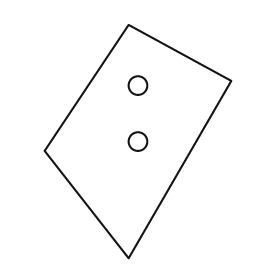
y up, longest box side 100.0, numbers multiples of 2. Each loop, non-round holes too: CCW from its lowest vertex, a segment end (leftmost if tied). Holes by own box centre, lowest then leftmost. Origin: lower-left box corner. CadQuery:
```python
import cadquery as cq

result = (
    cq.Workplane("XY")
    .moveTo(36.0, 0.0)
    .lineTo(80.0, 76.0)
    .lineTo(36.0, 100.0)
    .lineTo(0.0, 46.0)
    .close()
    .moveTo(40.0, 50.0)
    .circle(4.0)
    .moveTo(40.0, 74.0)
    .circle(4.0)
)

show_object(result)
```